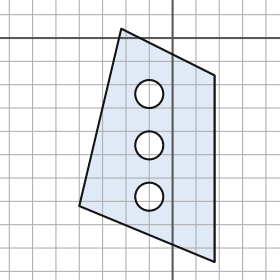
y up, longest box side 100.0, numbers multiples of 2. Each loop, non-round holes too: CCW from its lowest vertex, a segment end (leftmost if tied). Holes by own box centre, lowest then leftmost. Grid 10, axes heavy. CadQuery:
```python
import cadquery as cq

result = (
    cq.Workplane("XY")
    .moveTo(18.0, -96.0)
    .lineTo(18.0, -16.0)
    .lineTo(-22.0, 4.0)
    .lineTo(-40.0, -72.0)
    .close()
    .moveTo(-10.0, -68.0)
    .circle(6.0)
    .moveTo(-10.0, -46.0)
    .circle(6.0)
    .moveTo(-10.0, -24.0)
    .circle(6.0)
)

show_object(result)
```